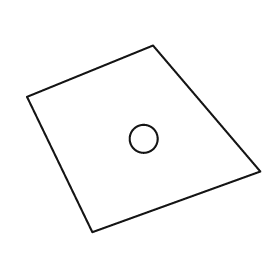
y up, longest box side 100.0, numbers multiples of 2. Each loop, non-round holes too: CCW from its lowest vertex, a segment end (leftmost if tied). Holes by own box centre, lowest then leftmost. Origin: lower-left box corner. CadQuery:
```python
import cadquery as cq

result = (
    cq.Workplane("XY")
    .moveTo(28.0, 0.0)
    .lineTo(100.0, 26.0)
    .lineTo(54.0, 80.0)
    .lineTo(0.0, 58.0)
    .close()
    .moveTo(50.0, 40.0)
    .circle(6.0)
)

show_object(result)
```